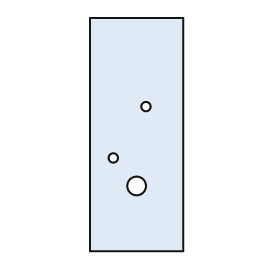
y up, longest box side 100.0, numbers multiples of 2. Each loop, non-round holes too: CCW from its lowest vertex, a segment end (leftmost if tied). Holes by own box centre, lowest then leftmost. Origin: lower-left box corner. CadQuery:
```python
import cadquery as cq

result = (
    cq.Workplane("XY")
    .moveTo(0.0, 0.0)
    .lineTo(40.0, 0.0)
    .lineTo(40.0, 100.0)
    .lineTo(0.0, 100.0)
    .close()
    .moveTo(20.0, 28.0)
    .circle(4.0)
    .moveTo(10.0, 40.0)
    .circle(2.0)
    .moveTo(24.0, 62.0)
    .circle(2.0)
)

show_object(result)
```